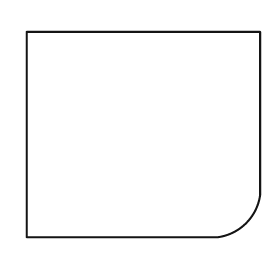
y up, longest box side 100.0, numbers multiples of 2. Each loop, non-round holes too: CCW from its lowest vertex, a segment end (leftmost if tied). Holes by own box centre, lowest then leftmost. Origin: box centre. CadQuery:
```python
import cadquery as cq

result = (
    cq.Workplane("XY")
    .moveTo(-50.0, -44.0)
    .lineTo(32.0, -44.0)
    .threePointArc((44.0, -38.0), (50.0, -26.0))
    .lineTo(50.0, 44.0)
    .lineTo(-50.0, 44.0)
    .close()
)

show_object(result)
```